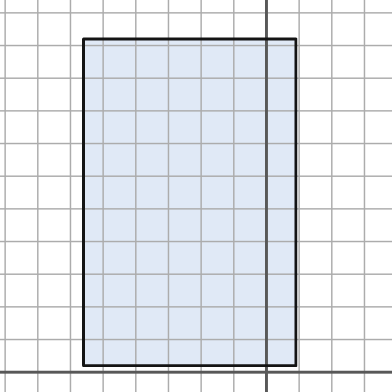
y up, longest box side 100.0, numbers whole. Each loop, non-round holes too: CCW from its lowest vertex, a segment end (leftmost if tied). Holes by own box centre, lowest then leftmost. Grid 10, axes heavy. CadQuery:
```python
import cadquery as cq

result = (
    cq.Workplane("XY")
    .moveTo(-56.0, 2.0)
    .lineTo(9.0, 2.0)
    .lineTo(9.0, 102.0)
    .lineTo(-56.0, 102.0)
    .close()
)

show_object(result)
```